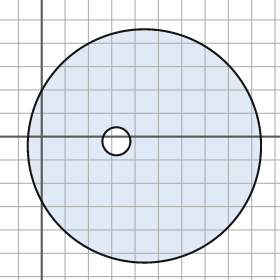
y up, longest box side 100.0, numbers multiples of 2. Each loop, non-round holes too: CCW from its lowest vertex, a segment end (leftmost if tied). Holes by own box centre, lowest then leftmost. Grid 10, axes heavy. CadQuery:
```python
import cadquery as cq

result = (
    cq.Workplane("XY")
    .moveTo(44.0, -4.0)
    .circle(50.0)
    .moveTo(32.0, -2.0)
    .circle(6.0)
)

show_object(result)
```